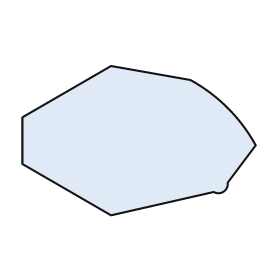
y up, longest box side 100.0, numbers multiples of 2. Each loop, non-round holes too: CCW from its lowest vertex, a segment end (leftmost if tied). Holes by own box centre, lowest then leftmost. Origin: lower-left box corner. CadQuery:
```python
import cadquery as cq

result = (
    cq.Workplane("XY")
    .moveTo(38.0, 0.0)
    .lineTo(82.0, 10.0)
    .threePointArc((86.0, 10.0), (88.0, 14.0))
    .lineTo(100.0, 30.0)
    .threePointArc((88.0, 46.0), (72.0, 58.0))
    .lineTo(38.0, 64.0)
    .lineTo(0.0, 42.0)
    .lineTo(0.0, 22.0)
    .close()
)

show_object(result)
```